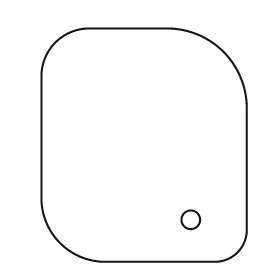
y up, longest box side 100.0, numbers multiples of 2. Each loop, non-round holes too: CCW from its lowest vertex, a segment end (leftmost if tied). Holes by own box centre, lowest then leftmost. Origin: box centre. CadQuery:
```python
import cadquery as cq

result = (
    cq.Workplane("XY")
    .moveTo(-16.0, -50.0)
    .lineTo(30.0, -50.0)
    .threePointArc((40.0, -46.0), (44.0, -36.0))
    .lineTo(44.0, 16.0)
    .threePointArc((34.0, 40.0), (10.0, 50.0))
    .lineTo(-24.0, 50.0)
    .threePointArc((-38.0, 44.0), (-44.0, 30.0))
    .lineTo(-44.0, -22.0)
    .threePointArc((-36.0, -42.0), (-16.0, -50.0))
    .close()
    .moveTo(20.0, -32.0)
    .circle(4.0)
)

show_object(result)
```